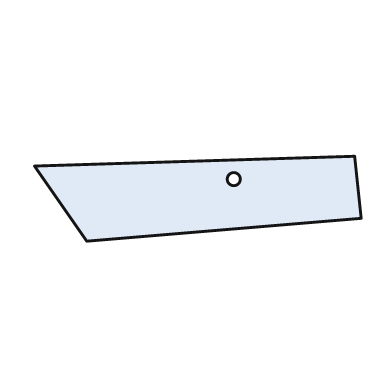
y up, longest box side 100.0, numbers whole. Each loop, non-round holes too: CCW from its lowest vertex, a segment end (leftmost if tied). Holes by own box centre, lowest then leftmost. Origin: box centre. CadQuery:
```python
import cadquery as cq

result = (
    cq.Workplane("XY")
    .moveTo(-34.0, -13.0)
    .lineTo(50.0, -6.0)
    .lineTo(48.0, 13.0)
    .lineTo(-50.0, 10.0)
    .close()
    .moveTo(11.0, 6.0)
    .circle(2.0)
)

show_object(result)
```